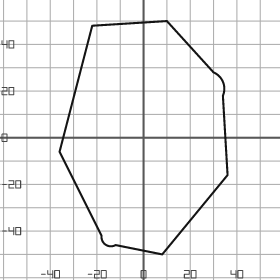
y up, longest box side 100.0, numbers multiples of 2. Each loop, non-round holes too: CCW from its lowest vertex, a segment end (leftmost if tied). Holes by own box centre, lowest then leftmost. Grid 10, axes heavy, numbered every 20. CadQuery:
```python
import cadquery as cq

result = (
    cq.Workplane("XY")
    .moveTo(8.0, -50.0)
    .lineTo(36.0, -16.0)
    .lineTo(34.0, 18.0)
    .threePointArc((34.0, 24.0), (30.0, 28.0))
    .lineTo(10.0, 50.0)
    .lineTo(-22.0, 48.0)
    .lineTo(-36.0, -6.0)
    .lineTo(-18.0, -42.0)
    .threePointArc((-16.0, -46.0), (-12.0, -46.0))
    .close()
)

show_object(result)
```